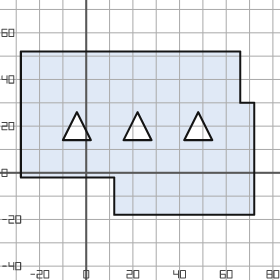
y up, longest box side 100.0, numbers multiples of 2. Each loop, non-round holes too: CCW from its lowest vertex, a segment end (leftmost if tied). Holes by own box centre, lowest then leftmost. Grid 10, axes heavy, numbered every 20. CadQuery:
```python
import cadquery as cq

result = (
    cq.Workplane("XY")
    .moveTo(12.0, -18.0)
    .lineTo(72.0, -18.0)
    .lineTo(72.0, 30.0)
    .lineTo(66.0, 30.0)
    .lineTo(66.0, 52.0)
    .lineTo(-28.0, 52.0)
    .lineTo(-28.0, -2.0)
    .lineTo(12.0, -2.0)
    .close()
    .moveTo(-10.0, 14.0)
    .lineTo(2.0, 14.0)
    .lineTo(-4.0, 26.0)
    .close()
    .moveTo(16.0, 14.0)
    .lineTo(28.0, 14.0)
    .lineTo(22.0, 26.0)
    .close()
    .moveTo(42.0, 14.0)
    .lineTo(54.0, 14.0)
    .lineTo(48.0, 26.0)
    .close()
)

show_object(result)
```